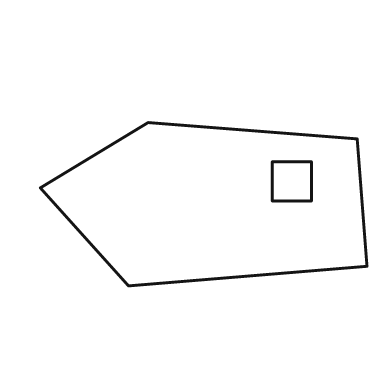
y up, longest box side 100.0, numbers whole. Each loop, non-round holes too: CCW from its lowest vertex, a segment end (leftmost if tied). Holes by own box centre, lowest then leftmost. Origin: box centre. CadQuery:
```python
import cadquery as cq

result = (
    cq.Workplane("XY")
    .moveTo(-23.0, -25.0)
    .lineTo(50.0, -19.0)
    .lineTo(47.0, 20.0)
    .lineTo(-17.0, 25.0)
    .lineTo(-50.0, 5.0)
    .close()
    .moveTo(21.0, 1.0)
    .lineTo(33.0, 1.0)
    .lineTo(33.0, 13.0)
    .lineTo(21.0, 13.0)
    .close()
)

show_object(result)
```